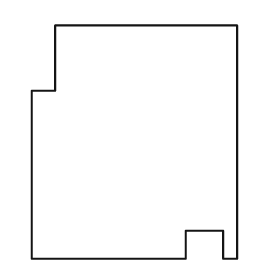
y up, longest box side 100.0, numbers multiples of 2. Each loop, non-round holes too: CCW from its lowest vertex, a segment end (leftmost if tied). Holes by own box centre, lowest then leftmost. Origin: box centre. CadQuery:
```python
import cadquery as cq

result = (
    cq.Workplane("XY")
    .moveTo(-44.0, -50.0)
    .lineTo(22.0, -50.0)
    .lineTo(22.0, -38.0)
    .lineTo(38.0, -38.0)
    .lineTo(38.0, -50.0)
    .lineTo(44.0, -50.0)
    .lineTo(44.0, 50.0)
    .lineTo(-34.0, 50.0)
    .lineTo(-34.0, 22.0)
    .lineTo(-44.0, 22.0)
    .close()
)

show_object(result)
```